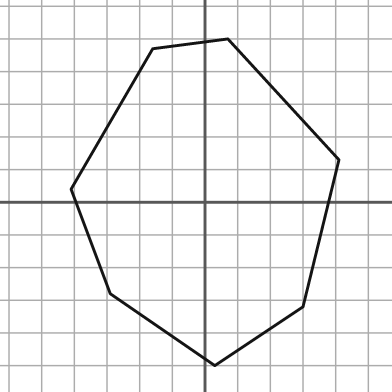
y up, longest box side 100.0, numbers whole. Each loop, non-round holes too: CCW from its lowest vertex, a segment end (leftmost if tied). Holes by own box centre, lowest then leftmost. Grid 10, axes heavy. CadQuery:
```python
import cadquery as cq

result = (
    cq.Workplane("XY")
    .moveTo(3.0, -50.0)
    .lineTo(30.0, -32.0)
    .lineTo(41.0, 13.0)
    .lineTo(7.0, 50.0)
    .lineTo(-16.0, 47.0)
    .lineTo(-41.0, 4.0)
    .lineTo(-29.0, -28.0)
    .close()
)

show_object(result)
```